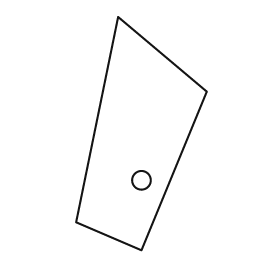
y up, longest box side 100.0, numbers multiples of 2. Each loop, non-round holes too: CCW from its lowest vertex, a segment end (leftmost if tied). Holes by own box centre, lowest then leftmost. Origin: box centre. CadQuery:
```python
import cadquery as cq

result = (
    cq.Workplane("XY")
    .moveTo(0.0, -50.0)
    .lineTo(28.0, 18.0)
    .lineTo(-10.0, 50.0)
    .lineTo(-28.0, -38.0)
    .close()
    .moveTo(0.0, -20.0)
    .circle(4.0)
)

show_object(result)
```